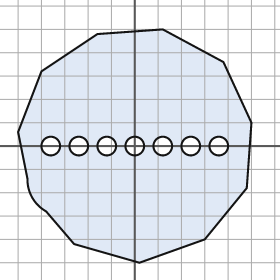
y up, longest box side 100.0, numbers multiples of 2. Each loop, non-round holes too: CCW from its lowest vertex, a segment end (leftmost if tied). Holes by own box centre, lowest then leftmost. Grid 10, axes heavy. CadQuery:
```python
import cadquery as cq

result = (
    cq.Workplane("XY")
    .moveTo(2.0, -50.0)
    .lineTo(30.0, -40.0)
    .lineTo(48.0, -18.0)
    .lineTo(50.0, 10.0)
    .lineTo(38.0, 36.0)
    .lineTo(12.0, 50.0)
    .lineTo(-16.0, 48.0)
    .lineTo(-40.0, 32.0)
    .lineTo(-50.0, 6.0)
    .lineTo(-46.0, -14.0)
    .threePointArc((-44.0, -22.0), (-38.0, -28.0))
    .lineTo(-26.0, -42.0)
    .close()
    .moveTo(-36.0, 0.0)
    .circle(4.0)
    .moveTo(-24.0, 0.0)
    .circle(4.0)
    .moveTo(-12.0, 0.0)
    .circle(4.0)
    .moveTo(0.0, 0.0)
    .circle(4.0)
    .moveTo(12.0, 0.0)
    .circle(4.0)
    .moveTo(24.0, 0.0)
    .circle(4.0)
    .moveTo(36.0, 0.0)
    .circle(4.0)
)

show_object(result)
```